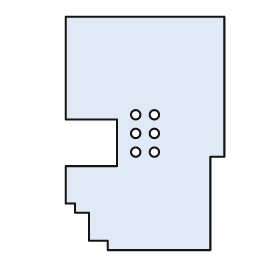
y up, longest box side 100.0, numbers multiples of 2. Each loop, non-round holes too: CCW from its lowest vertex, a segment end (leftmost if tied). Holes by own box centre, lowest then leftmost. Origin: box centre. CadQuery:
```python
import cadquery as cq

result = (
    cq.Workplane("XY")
    .moveTo(-16.0, -50.0)
    .lineTo(28.0, -50.0)
    .lineTo(28.0, -10.0)
    .lineTo(34.0, -10.0)
    .lineTo(34.0, 50.0)
    .lineTo(-34.0, 50.0)
    .lineTo(-34.0, 6.0)
    .lineTo(-12.0, 6.0)
    .lineTo(-12.0, -14.0)
    .lineTo(-34.0, -14.0)
    .lineTo(-34.0, -30.0)
    .lineTo(-30.0, -30.0)
    .lineTo(-30.0, -34.0)
    .lineTo(-24.0, -34.0)
    .lineTo(-24.0, -46.0)
    .lineTo(-16.0, -46.0)
    .close()
    .moveTo(-4.0, -8.0)
    .circle(2.0)
    .moveTo(4.0, -8.0)
    .circle(2.0)
    .moveTo(-4.0, 0.0)
    .circle(2.0)
    .moveTo(4.0, 0.0)
    .circle(2.0)
    .moveTo(-4.0, 8.0)
    .circle(2.0)
    .moveTo(4.0, 8.0)
    .circle(2.0)
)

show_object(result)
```